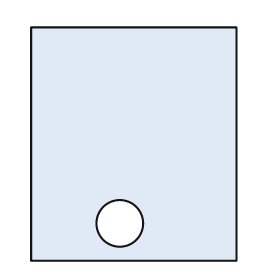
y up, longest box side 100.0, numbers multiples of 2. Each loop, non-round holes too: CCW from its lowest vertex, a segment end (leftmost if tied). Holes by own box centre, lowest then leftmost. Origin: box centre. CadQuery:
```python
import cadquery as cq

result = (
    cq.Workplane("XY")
    .moveTo(-44.0, -50.0)
    .lineTo(44.0, -50.0)
    .lineTo(44.0, 50.0)
    .lineTo(-44.0, 50.0)
    .close()
    .moveTo(-6.0, -34.0)
    .circle(10.0)
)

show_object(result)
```